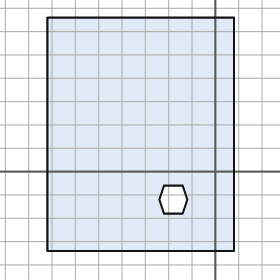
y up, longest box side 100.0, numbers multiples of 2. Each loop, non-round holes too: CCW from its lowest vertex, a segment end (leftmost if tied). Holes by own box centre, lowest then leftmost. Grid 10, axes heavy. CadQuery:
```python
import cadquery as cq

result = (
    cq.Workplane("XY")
    .moveTo(-72.0, -34.0)
    .lineTo(8.0, -34.0)
    .lineTo(8.0, 66.0)
    .lineTo(-72.0, 66.0)
    .close()
    .moveTo(-22.0, -18.0)
    .lineTo(-14.0, -18.0)
    .lineTo(-12.0, -12.0)
    .lineTo(-14.0, -6.0)
    .lineTo(-22.0, -6.0)
    .lineTo(-24.0, -12.0)
    .close()
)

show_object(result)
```